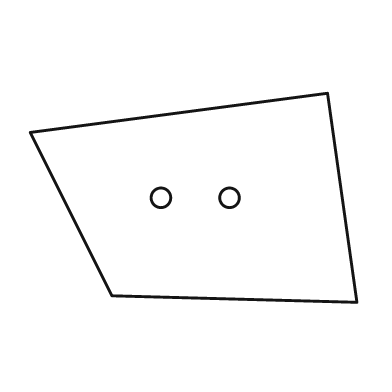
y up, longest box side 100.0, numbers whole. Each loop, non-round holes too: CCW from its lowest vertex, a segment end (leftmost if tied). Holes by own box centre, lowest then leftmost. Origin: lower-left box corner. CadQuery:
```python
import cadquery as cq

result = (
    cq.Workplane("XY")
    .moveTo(100.0, 0.0)
    .lineTo(91.0, 64.0)
    .lineTo(0.0, 52.0)
    .lineTo(25.0, 2.0)
    .close()
    .moveTo(40.0, 32.0)
    .circle(3.0)
    .moveTo(61.0, 32.0)
    .circle(3.0)
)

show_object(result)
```